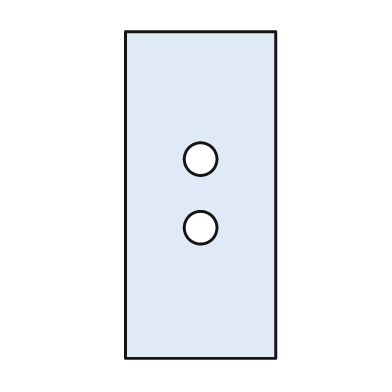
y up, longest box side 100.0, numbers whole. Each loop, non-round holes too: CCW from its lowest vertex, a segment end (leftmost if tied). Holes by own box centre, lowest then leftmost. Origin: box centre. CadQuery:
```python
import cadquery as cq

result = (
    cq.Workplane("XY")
    .moveTo(-23.0, -50.0)
    .lineTo(23.0, -50.0)
    .lineTo(23.0, 50.0)
    .lineTo(-23.0, 50.0)
    .close()
    .moveTo(0.0, -10.0)
    .circle(5.0)
    .moveTo(0.0, 11.0)
    .circle(5.0)
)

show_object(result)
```